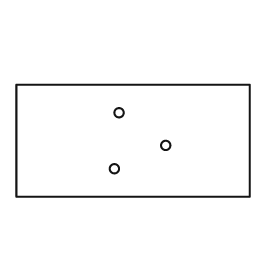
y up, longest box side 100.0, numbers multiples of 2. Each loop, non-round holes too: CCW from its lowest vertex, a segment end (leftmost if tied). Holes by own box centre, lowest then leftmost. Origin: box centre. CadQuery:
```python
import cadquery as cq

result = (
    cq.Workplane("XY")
    .moveTo(-50.0, -24.0)
    .lineTo(50.0, -24.0)
    .lineTo(50.0, 24.0)
    .lineTo(-50.0, 24.0)
    .close()
    .moveTo(-8.0, -12.0)
    .circle(2.0)
    .moveTo(14.0, -2.0)
    .circle(2.0)
    .moveTo(-6.0, 12.0)
    .circle(2.0)
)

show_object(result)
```